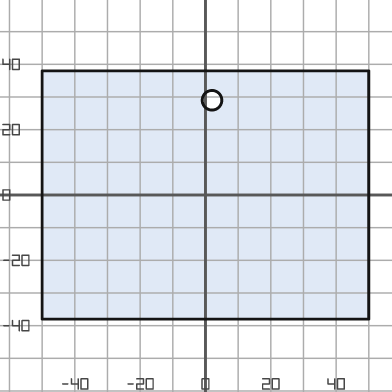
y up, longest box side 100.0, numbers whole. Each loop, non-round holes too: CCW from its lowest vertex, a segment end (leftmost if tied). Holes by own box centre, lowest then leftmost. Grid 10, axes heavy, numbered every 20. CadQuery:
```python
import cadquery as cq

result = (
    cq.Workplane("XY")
    .moveTo(-50.0, -38.0)
    .lineTo(50.0, -38.0)
    .lineTo(50.0, 38.0)
    .lineTo(-50.0, 38.0)
    .close()
    .moveTo(2.0, 29.0)
    .circle(3.0)
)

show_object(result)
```